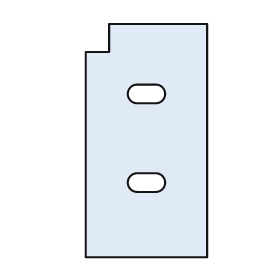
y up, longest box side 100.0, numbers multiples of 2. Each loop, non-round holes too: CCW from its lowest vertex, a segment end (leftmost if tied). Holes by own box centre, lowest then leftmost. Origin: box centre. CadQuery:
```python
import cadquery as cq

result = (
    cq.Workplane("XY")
    .moveTo(-26.0, -50.0)
    .lineTo(26.0, -50.0)
    .lineTo(26.0, 50.0)
    .lineTo(-16.0, 50.0)
    .lineTo(-16.0, 38.0)
    .lineTo(-26.0, 38.0)
    .close()
    .moveTo(-4.0, -22.0)
    .lineTo(4.0, -22.0)
    .threePointArc((8.0, -18.0), (4.0, -14.0))
    .lineTo(-4.0, -14.0)
    .threePointArc((-8.0, -18.0), (-4.0, -22.0))
    .close()
    .moveTo(-4.0, 16.0)
    .lineTo(4.0, 16.0)
    .threePointArc((8.0, 20.0), (4.0, 24.0))
    .lineTo(-4.0, 24.0)
    .threePointArc((-8.0, 20.0), (-4.0, 16.0))
    .close()
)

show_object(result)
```